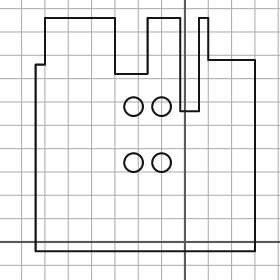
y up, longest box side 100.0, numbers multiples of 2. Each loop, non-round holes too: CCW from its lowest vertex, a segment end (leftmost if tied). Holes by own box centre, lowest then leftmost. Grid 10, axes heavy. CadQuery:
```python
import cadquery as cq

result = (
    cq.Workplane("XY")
    .moveTo(-64.0, -4.0)
    .lineTo(30.0, -4.0)
    .lineTo(30.0, 78.0)
    .lineTo(10.0, 78.0)
    .lineTo(10.0, 96.0)
    .lineTo(6.0, 96.0)
    .lineTo(6.0, 56.0)
    .lineTo(-2.0, 56.0)
    .lineTo(-2.0, 96.0)
    .lineTo(-16.0, 96.0)
    .lineTo(-16.0, 72.0)
    .lineTo(-30.0, 72.0)
    .lineTo(-30.0, 96.0)
    .lineTo(-60.0, 96.0)
    .lineTo(-60.0, 76.0)
    .lineTo(-64.0, 76.0)
    .close()
    .moveTo(-22.0, 34.0)
    .circle(4.0)
    .moveTo(-10.0, 34.0)
    .circle(4.0)
    .moveTo(-22.0, 58.0)
    .circle(4.0)
    .moveTo(-10.0, 58.0)
    .circle(4.0)
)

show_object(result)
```